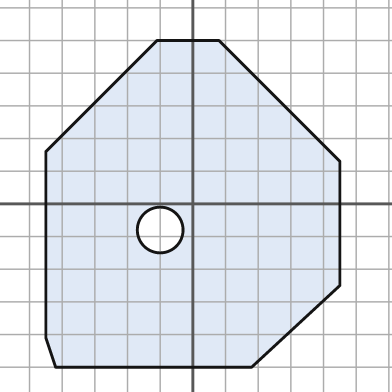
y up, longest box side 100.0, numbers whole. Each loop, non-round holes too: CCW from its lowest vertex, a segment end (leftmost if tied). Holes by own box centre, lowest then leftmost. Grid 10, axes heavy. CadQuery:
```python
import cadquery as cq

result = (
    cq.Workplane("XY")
    .moveTo(-42.0, -50.0)
    .lineTo(18.0, -50.0)
    .lineTo(45.0, -25.0)
    .lineTo(45.0, 13.0)
    .lineTo(8.0, 50.0)
    .lineTo(-11.0, 50.0)
    .lineTo(-45.0, 16.0)
    .lineTo(-45.0, -41.0)
    .close()
    .moveTo(-10.0, -8.0)
    .circle(7.0)
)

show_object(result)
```